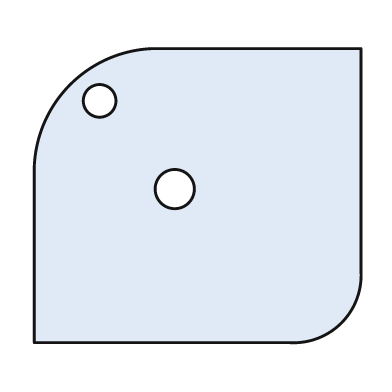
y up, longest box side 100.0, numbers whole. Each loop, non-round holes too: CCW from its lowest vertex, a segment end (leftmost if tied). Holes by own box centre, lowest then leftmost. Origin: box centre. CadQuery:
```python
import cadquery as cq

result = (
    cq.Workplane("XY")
    .moveTo(-50.0, -45.0)
    .lineTo(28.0, -45.0)
    .threePointArc((44.0, -39.0), (50.0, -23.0))
    .lineTo(50.0, 45.0)
    .lineTo(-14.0, 45.0)
    .threePointArc((-39.0, 34.0), (-50.0, 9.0))
    .close()
    .moveTo(-7.0, 2.0)
    .circle(6.0)
    .moveTo(-30.0, 29.0)
    .circle(5.0)
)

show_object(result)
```